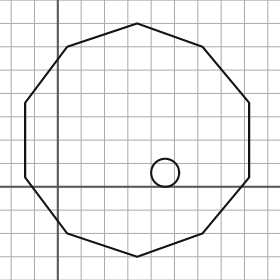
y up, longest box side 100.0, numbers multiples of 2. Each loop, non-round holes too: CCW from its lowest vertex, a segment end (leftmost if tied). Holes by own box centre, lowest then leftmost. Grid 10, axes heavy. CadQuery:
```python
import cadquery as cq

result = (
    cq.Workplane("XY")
    .moveTo(34.0, -30.0)
    .lineTo(62.0, -20.0)
    .lineTo(82.0, 4.0)
    .lineTo(82.0, 36.0)
    .lineTo(62.0, 60.0)
    .lineTo(34.0, 70.0)
    .lineTo(4.0, 60.0)
    .lineTo(-14.0, 36.0)
    .lineTo(-14.0, 4.0)
    .lineTo(4.0, -20.0)
    .close()
    .moveTo(46.0, 6.0)
    .circle(6.0)
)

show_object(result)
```